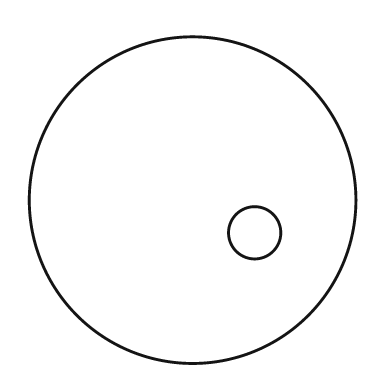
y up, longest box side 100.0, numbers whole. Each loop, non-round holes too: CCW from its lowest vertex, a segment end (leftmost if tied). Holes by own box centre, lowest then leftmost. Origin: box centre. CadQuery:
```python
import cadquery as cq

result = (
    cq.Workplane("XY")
    .moveTo(0.0, 0.0)
    .circle(50.0)
    .moveTo(19.0, -10.0)
    .circle(8.0)
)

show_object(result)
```